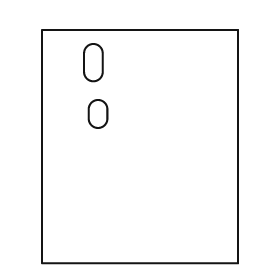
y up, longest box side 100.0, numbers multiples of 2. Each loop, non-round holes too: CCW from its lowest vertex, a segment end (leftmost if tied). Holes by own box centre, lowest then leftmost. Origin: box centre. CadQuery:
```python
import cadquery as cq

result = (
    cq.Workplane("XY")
    .moveTo(-42.0, -50.0)
    .lineTo(42.0, -50.0)
    .lineTo(42.0, 50.0)
    .lineTo(-42.0, 50.0)
    .close()
    .moveTo(-22.0, 12.0)
    .threePointArc((-18.0, 8.0), (-14.0, 12.0))
    .lineTo(-14.0, 16.0)
    .threePointArc((-18.0, 20.0), (-22.0, 16.0))
    .close()
    .moveTo(-24.0, 32.0)
    .threePointArc((-20.0, 28.0), (-16.0, 32.0))
    .lineTo(-16.0, 40.0)
    .threePointArc((-20.0, 44.0), (-24.0, 40.0))
    .close()
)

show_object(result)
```